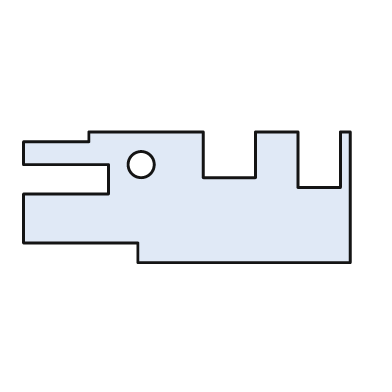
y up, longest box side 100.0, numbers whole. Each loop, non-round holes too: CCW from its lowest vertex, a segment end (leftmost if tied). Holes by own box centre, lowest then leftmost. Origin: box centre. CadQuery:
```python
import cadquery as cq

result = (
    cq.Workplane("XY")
    .moveTo(-15.0, -20.0)
    .lineTo(50.0, -20.0)
    .lineTo(50.0, 20.0)
    .lineTo(47.0, 20.0)
    .lineTo(47.0, 3.0)
    .lineTo(34.0, 3.0)
    .lineTo(34.0, 20.0)
    .lineTo(21.0, 20.0)
    .lineTo(21.0, 6.0)
    .lineTo(5.0, 6.0)
    .lineTo(5.0, 20.0)
    .lineTo(-30.0, 20.0)
    .lineTo(-30.0, 17.0)
    .lineTo(-50.0, 17.0)
    .lineTo(-50.0, 10.0)
    .lineTo(-24.0, 10.0)
    .lineTo(-24.0, 1.0)
    .lineTo(-50.0, 1.0)
    .lineTo(-50.0, -14.0)
    .lineTo(-15.0, -14.0)
    .close()
    .moveTo(-14.0, 10.0)
    .circle(4.0)
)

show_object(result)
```